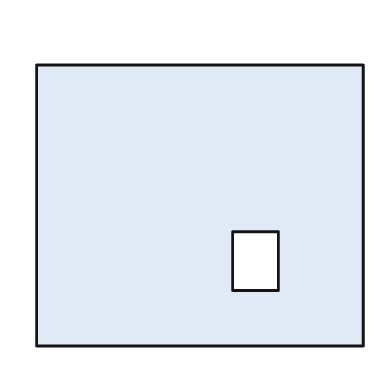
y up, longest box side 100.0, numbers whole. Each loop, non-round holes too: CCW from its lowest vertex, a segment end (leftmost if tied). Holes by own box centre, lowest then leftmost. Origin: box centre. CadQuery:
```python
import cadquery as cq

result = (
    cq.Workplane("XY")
    .moveTo(-50.0, -43.0)
    .lineTo(50.0, -43.0)
    .lineTo(50.0, 43.0)
    .lineTo(-50.0, 43.0)
    .close()
    .moveTo(10.0, -26.0)
    .lineTo(24.0, -26.0)
    .lineTo(24.0, -8.0)
    .lineTo(10.0, -8.0)
    .close()
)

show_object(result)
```